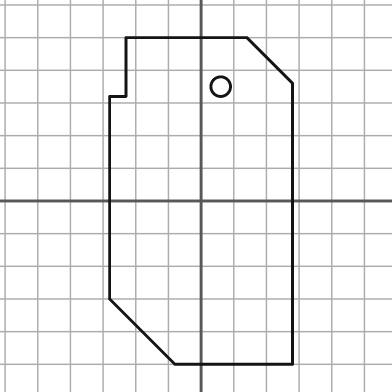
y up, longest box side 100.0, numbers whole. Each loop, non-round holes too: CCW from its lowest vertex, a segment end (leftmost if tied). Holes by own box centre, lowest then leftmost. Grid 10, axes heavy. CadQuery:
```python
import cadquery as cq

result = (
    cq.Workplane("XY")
    .moveTo(-8.0, -50.0)
    .lineTo(28.0, -50.0)
    .lineTo(28.0, 36.0)
    .lineTo(14.0, 50.0)
    .lineTo(-23.0, 50.0)
    .lineTo(-23.0, 32.0)
    .lineTo(-28.0, 32.0)
    .lineTo(-28.0, -30.0)
    .close()
    .moveTo(6.0, 35.0)
    .circle(3.0)
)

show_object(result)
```